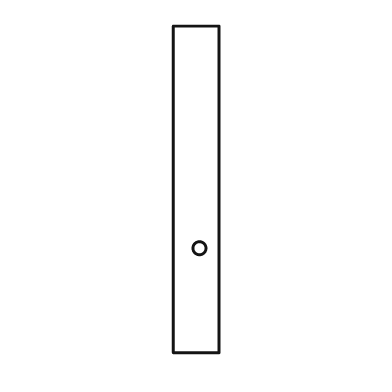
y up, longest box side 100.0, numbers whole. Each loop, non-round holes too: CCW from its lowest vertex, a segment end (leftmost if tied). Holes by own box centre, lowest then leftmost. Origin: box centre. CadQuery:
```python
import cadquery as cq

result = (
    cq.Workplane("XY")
    .moveTo(-7.0, -50.0)
    .lineTo(7.0, -50.0)
    .lineTo(7.0, 50.0)
    .lineTo(-7.0, 50.0)
    .close()
    .moveTo(1.0, -18.0)
    .circle(2.0)
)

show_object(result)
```